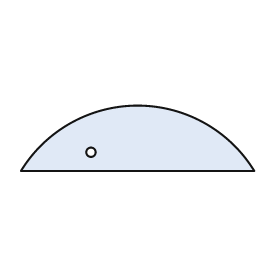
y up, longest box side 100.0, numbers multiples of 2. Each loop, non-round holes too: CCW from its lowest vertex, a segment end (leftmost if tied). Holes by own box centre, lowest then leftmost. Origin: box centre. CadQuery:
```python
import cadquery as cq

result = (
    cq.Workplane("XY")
    .moveTo(-50.0, -14.0)
    .lineTo(50.0, -14.0)
    .threePointArc((0.0, 14.0), (-50.0, -14.0))
    .close()
    .moveTo(-20.0, -6.0)
    .circle(2.0)
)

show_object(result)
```